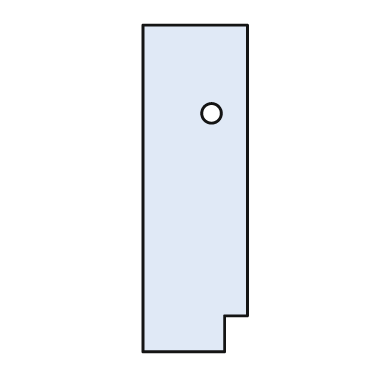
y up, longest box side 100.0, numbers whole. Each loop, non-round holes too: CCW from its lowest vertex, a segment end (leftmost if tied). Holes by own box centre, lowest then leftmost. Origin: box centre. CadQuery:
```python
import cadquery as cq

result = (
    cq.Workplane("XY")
    .moveTo(-16.0, -50.0)
    .lineTo(9.0, -50.0)
    .lineTo(9.0, -39.0)
    .lineTo(16.0, -39.0)
    .lineTo(16.0, 50.0)
    .lineTo(-16.0, 50.0)
    .close()
    .moveTo(5.0, 23.0)
    .circle(3.0)
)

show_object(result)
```